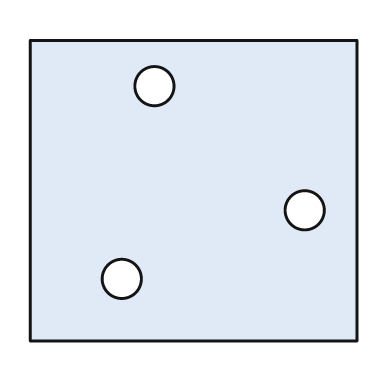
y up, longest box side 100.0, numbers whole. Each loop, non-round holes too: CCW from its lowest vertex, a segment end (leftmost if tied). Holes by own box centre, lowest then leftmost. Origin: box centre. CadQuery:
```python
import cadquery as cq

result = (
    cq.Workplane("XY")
    .moveTo(-50.0, -46.0)
    .lineTo(50.0, -46.0)
    .lineTo(50.0, 46.0)
    .lineTo(-50.0, 46.0)
    .close()
    .moveTo(-22.0, -27.0)
    .circle(6.0)
    .moveTo(34.0, -6.0)
    .circle(6.0)
    .moveTo(-12.0, 32.0)
    .circle(6.0)
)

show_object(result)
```